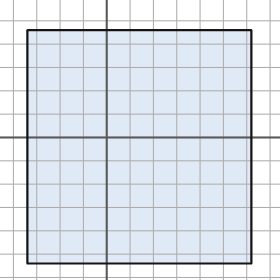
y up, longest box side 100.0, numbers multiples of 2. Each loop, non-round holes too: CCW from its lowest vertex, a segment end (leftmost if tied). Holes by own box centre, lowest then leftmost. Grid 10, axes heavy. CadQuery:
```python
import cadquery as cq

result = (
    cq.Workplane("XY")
    .moveTo(-34.0, -54.0)
    .lineTo(62.0, -54.0)
    .lineTo(62.0, 46.0)
    .lineTo(-34.0, 46.0)
    .close()
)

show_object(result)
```